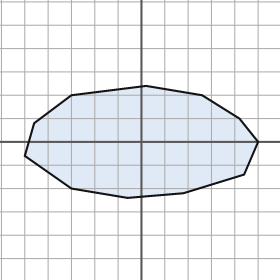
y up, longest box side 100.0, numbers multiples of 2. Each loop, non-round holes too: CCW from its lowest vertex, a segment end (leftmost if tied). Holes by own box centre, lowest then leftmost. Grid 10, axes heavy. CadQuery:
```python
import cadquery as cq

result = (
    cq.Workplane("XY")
    .moveTo(-6.0, -24.0)
    .lineTo(18.0, -22.0)
    .lineTo(44.0, -14.0)
    .lineTo(50.0, 0.0)
    .lineTo(42.0, 10.0)
    .lineTo(26.0, 20.0)
    .lineTo(2.0, 24.0)
    .lineTo(-30.0, 20.0)
    .lineTo(-46.0, 8.0)
    .lineTo(-50.0, -6.0)
    .lineTo(-30.0, -20.0)
    .close()
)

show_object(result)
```